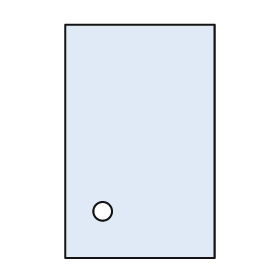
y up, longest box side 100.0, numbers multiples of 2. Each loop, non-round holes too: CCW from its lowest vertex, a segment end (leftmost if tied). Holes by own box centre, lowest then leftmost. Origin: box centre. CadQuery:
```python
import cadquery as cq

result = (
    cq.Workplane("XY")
    .moveTo(-32.0, -50.0)
    .lineTo(32.0, -50.0)
    .lineTo(32.0, 50.0)
    .lineTo(-32.0, 50.0)
    .close()
    .moveTo(-16.0, -30.0)
    .circle(4.0)
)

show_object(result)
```